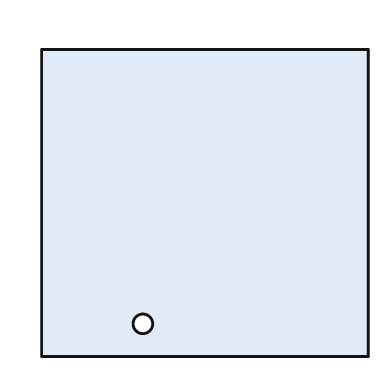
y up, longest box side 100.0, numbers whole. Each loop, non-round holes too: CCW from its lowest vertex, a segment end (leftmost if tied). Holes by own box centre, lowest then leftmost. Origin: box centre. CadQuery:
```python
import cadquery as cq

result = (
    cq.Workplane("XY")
    .moveTo(-50.0, -47.0)
    .lineTo(50.0, -47.0)
    .lineTo(50.0, 47.0)
    .lineTo(-50.0, 47.0)
    .close()
    .moveTo(-19.0, -37.0)
    .circle(3.0)
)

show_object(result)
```